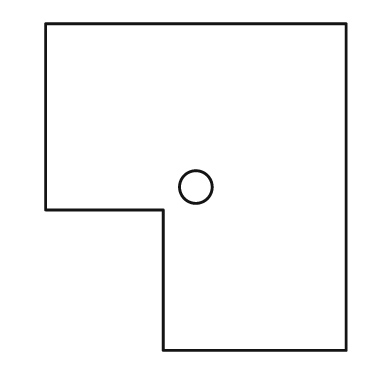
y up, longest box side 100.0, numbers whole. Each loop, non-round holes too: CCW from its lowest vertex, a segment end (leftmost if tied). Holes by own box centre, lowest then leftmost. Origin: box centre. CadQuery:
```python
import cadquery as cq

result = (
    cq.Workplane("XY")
    .moveTo(-10.0, -50.0)
    .lineTo(46.0, -50.0)
    .lineTo(46.0, 50.0)
    .lineTo(-46.0, 50.0)
    .lineTo(-46.0, -7.0)
    .lineTo(-10.0, -7.0)
    .close()
    .moveTo(0.0, 0.0)
    .circle(5.0)
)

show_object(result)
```